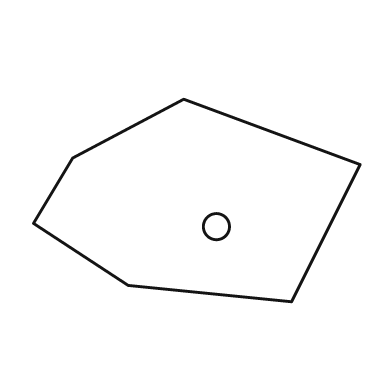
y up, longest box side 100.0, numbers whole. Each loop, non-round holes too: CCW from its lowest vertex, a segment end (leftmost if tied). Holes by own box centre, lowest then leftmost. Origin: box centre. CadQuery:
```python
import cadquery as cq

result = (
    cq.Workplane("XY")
    .moveTo(29.0, -31.0)
    .lineTo(50.0, 11.0)
    .lineTo(-4.0, 31.0)
    .lineTo(-38.0, 13.0)
    .lineTo(-50.0, -7.0)
    .lineTo(-21.0, -26.0)
    .close()
    .moveTo(6.0, -8.0)
    .circle(4.0)
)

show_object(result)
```